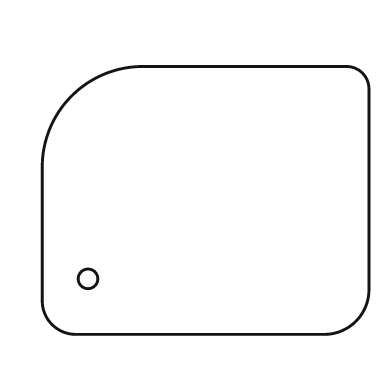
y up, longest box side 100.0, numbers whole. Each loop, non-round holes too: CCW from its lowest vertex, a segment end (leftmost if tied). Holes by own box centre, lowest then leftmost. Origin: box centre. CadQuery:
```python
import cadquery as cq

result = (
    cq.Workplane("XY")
    .moveTo(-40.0, -41.0)
    .lineTo(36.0, -41.0)
    .threePointArc((46.0, -37.0), (50.0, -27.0))
    .lineTo(50.0, 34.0)
    .threePointArc((48.0, 39.0), (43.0, 41.0))
    .lineTo(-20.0, 41.0)
    .threePointArc((-41.0, 32.0), (-50.0, 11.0))
    .lineTo(-50.0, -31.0)
    .threePointArc((-47.0, -38.0), (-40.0, -41.0))
    .close()
    .moveTo(-36.0, -24.0)
    .circle(3.0)
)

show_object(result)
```